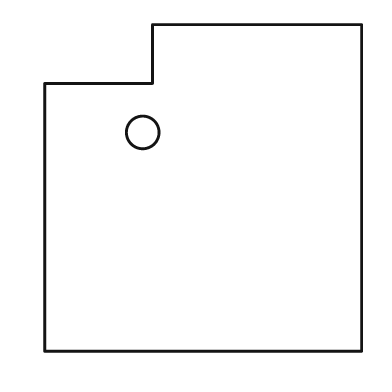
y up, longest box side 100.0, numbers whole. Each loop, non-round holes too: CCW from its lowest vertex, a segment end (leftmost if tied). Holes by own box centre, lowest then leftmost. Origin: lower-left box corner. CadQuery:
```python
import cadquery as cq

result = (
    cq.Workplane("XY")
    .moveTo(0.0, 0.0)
    .lineTo(97.0, 0.0)
    .lineTo(97.0, 100.0)
    .lineTo(33.0, 100.0)
    .lineTo(33.0, 82.0)
    .lineTo(0.0, 82.0)
    .close()
    .moveTo(30.0, 67.0)
    .circle(5.0)
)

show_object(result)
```